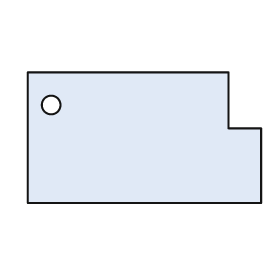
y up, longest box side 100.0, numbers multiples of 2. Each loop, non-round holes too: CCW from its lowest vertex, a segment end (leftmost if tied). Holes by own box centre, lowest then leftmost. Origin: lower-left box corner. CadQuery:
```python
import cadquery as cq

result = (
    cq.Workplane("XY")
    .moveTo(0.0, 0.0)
    .lineTo(100.0, 0.0)
    .lineTo(100.0, 32.0)
    .lineTo(86.0, 32.0)
    .lineTo(86.0, 56.0)
    .lineTo(0.0, 56.0)
    .close()
    .moveTo(10.0, 42.0)
    .circle(4.0)
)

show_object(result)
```